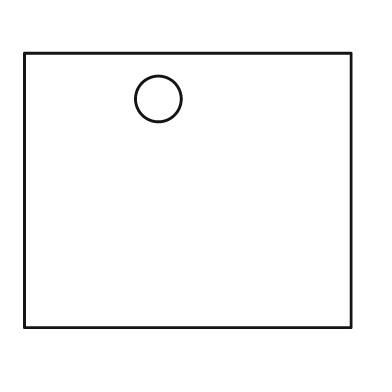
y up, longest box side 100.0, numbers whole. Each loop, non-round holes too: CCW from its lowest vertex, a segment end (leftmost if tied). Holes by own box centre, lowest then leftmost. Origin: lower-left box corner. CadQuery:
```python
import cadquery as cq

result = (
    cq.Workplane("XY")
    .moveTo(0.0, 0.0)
    .lineTo(100.0, 0.0)
    .lineTo(100.0, 84.0)
    .lineTo(0.0, 84.0)
    .close()
    .moveTo(41.0, 70.0)
    .circle(7.0)
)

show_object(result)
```